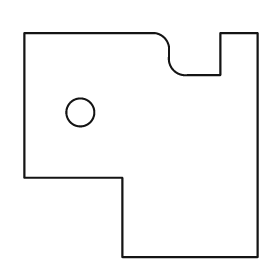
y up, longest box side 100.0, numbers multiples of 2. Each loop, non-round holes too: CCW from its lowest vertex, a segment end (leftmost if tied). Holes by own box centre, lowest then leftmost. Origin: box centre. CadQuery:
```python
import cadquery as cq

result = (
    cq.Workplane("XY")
    .moveTo(-8.0, -48.0)
    .lineTo(50.0, -48.0)
    .lineTo(50.0, 48.0)
    .lineTo(34.0, 48.0)
    .lineTo(34.0, 30.0)
    .lineTo(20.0, 30.0)
    .threePointArc((14.0, 32.0), (12.0, 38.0))
    .lineTo(12.0, 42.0)
    .threePointArc((10.0, 46.0), (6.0, 48.0))
    .lineTo(-50.0, 48.0)
    .lineTo(-50.0, -14.0)
    .lineTo(-8.0, -14.0)
    .close()
    .moveTo(-26.0, 14.0)
    .circle(6.0)
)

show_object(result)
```